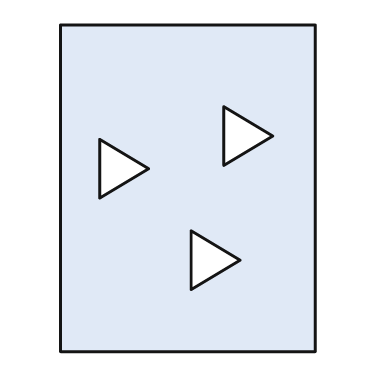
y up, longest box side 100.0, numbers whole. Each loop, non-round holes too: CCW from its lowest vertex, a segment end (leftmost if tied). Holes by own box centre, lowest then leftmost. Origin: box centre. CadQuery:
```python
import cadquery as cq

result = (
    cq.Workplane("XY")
    .moveTo(-39.0, -50.0)
    .lineTo(39.0, -50.0)
    .lineTo(39.0, 50.0)
    .lineTo(-39.0, 50.0)
    .close()
    .moveTo(1.0, -31.0)
    .lineTo(16.0, -22.0)
    .lineTo(1.0, -13.0)
    .close()
    .moveTo(-27.0, -3.0)
    .lineTo(-12.0, 6.0)
    .lineTo(-27.0, 15.0)
    .close()
    .moveTo(11.0, 7.0)
    .lineTo(26.0, 16.0)
    .lineTo(11.0, 25.0)
    .close()
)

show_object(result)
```